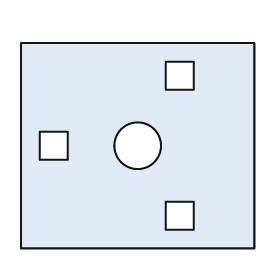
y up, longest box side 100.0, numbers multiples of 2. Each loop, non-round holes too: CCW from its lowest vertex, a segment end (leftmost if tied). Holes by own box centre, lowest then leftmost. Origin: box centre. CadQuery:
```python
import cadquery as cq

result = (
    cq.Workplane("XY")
    .moveTo(-50.0, -44.0)
    .lineTo(50.0, -44.0)
    .lineTo(50.0, 44.0)
    .lineTo(-50.0, 44.0)
    .close()
    .moveTo(12.0, -36.0)
    .lineTo(24.0, -36.0)
    .lineTo(24.0, -24.0)
    .lineTo(12.0, -24.0)
    .close()
    .moveTo(-42.0, -6.0)
    .lineTo(-30.0, -6.0)
    .lineTo(-30.0, 6.0)
    .lineTo(-42.0, 6.0)
    .close()
    .moveTo(0.0, 0.0)
    .circle(10.0)
    .moveTo(12.0, 24.0)
    .lineTo(24.0, 24.0)
    .lineTo(24.0, 36.0)
    .lineTo(12.0, 36.0)
    .close()
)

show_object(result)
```